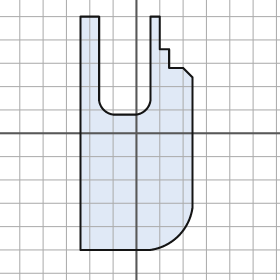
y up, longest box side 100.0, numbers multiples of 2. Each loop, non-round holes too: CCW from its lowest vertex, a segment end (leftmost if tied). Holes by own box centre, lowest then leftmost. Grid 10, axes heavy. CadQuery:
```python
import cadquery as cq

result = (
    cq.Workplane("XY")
    .moveTo(-24.0, -50.0)
    .lineTo(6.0, -50.0)
    .threePointArc((18.0, -44.0), (24.0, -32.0))
    .lineTo(24.0, 24.0)
    .lineTo(20.0, 28.0)
    .lineTo(14.0, 28.0)
    .lineTo(14.0, 36.0)
    .lineTo(10.0, 36.0)
    .lineTo(10.0, 50.0)
    .lineTo(6.0, 50.0)
    .lineTo(6.0, 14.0)
    .threePointArc((4.0, 10.0), (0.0, 8.0))
    .lineTo(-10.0, 8.0)
    .threePointArc((-14.0, 10.0), (-16.0, 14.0))
    .lineTo(-16.0, 50.0)
    .lineTo(-24.0, 50.0)
    .close()
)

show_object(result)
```